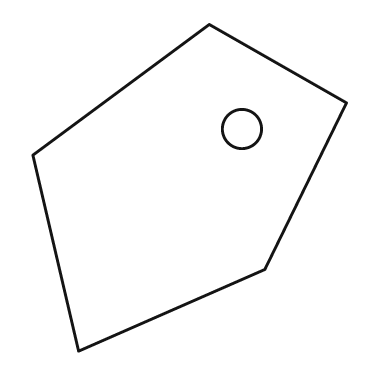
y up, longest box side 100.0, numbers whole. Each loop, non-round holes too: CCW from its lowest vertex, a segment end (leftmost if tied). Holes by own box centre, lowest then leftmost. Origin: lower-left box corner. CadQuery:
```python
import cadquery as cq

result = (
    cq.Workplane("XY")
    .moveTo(14.0, 0.0)
    .lineTo(71.0, 25.0)
    .lineTo(96.0, 76.0)
    .lineTo(54.0, 100.0)
    .lineTo(0.0, 60.0)
    .close()
    .moveTo(64.0, 68.0)
    .circle(6.0)
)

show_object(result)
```